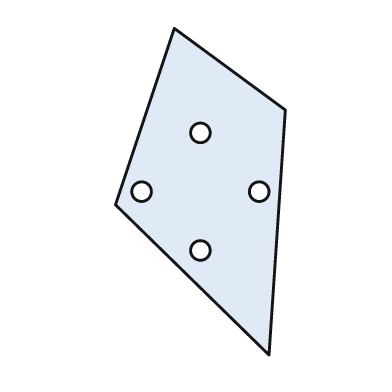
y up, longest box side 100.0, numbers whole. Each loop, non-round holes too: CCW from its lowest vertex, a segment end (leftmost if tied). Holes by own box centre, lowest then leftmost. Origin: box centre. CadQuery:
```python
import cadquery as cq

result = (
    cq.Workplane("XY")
    .moveTo(21.0, -50.0)
    .lineTo(26.0, 25.0)
    .lineTo(-8.0, 50.0)
    .lineTo(-26.0, -4.0)
    .close()
    .moveTo(0.0, -18.0)
    .circle(3.0)
    .moveTo(-18.0, 0.0)
    .circle(3.0)
    .moveTo(18.0, 0.0)
    .circle(3.0)
    .moveTo(0.0, 18.0)
    .circle(3.0)
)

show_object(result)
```